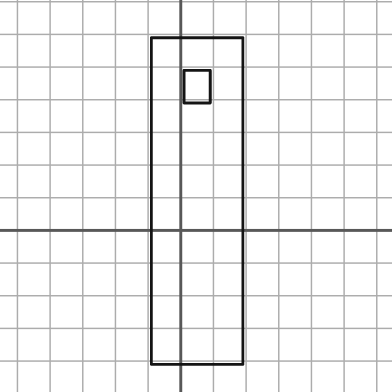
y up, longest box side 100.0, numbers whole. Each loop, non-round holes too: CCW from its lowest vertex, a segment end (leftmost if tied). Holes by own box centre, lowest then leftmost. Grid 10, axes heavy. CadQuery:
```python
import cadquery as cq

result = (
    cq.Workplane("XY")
    .moveTo(-9.0, -41.0)
    .lineTo(19.0, -41.0)
    .lineTo(19.0, 59.0)
    .lineTo(-9.0, 59.0)
    .close()
    .moveTo(1.0, 39.0)
    .lineTo(9.0, 39.0)
    .lineTo(9.0, 49.0)
    .lineTo(1.0, 49.0)
    .close()
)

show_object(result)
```